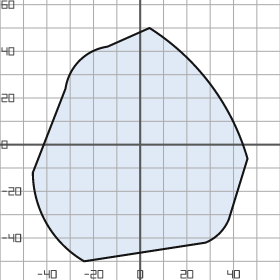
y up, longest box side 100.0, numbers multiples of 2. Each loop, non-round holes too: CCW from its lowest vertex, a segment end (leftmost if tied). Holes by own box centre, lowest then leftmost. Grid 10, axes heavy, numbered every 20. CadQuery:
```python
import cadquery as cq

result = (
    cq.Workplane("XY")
    .moveTo(-24.0, -50.0)
    .lineTo(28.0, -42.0)
    .threePointArc((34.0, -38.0), (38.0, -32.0))
    .lineTo(46.0, -6.0)
    .threePointArc((30.0, 26.0), (4.0, 50.0))
    .lineTo(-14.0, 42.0)
    .threePointArc((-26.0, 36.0), (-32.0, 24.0))
    .lineTo(-46.0, -12.0)
    .threePointArc((-40.0, -34.0), (-24.0, -50.0))
    .close()
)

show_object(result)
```